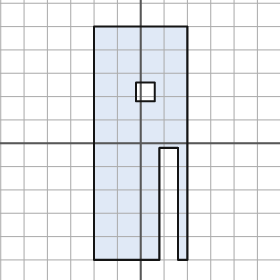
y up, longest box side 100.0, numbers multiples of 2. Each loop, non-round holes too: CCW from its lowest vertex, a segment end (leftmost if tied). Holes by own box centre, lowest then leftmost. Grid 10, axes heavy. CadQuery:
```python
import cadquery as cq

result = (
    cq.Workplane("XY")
    .moveTo(-20.0, -50.0)
    .lineTo(8.0, -50.0)
    .lineTo(8.0, -2.0)
    .lineTo(16.0, -2.0)
    .lineTo(16.0, -50.0)
    .lineTo(20.0, -50.0)
    .lineTo(20.0, 50.0)
    .lineTo(-20.0, 50.0)
    .close()
    .moveTo(-2.0, 18.0)
    .lineTo(6.0, 18.0)
    .lineTo(6.0, 26.0)
    .lineTo(-2.0, 26.0)
    .close()
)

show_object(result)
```